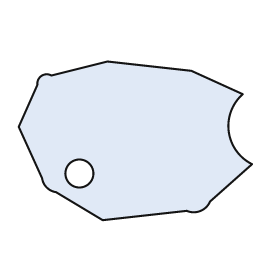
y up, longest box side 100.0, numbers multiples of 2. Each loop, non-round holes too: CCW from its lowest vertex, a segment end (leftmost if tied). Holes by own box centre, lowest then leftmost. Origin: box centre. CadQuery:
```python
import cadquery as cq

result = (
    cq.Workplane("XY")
    .moveTo(-14.0, -34.0)
    .lineTo(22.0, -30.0)
    .threePointArc((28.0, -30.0), (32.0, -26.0))
    .lineTo(50.0, -10.0)
    .threePointArc((40.0, 4.0), (46.0, 20.0))
    .lineTo(24.0, 30.0)
    .lineTo(-12.0, 34.0)
    .lineTo(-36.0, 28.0)
    .threePointArc((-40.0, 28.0), (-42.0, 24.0))
    .lineTo(-50.0, 6.0)
    .lineTo(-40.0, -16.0)
    .threePointArc((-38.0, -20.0), (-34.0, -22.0))
    .close()
    .moveTo(-24.0, -14.0)
    .circle(6.0)
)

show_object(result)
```